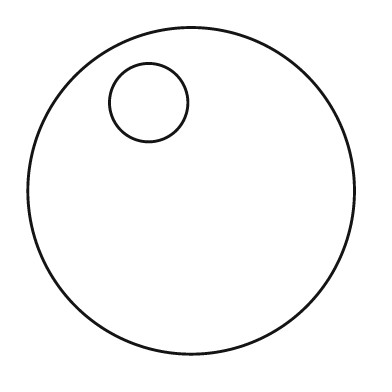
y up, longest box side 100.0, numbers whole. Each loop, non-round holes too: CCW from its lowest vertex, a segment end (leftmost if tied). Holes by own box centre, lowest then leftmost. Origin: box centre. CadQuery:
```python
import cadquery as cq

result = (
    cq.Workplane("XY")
    .moveTo(0.0, 0.0)
    .circle(50.0)
    .moveTo(-13.0, 27.0)
    .circle(12.0)
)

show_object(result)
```